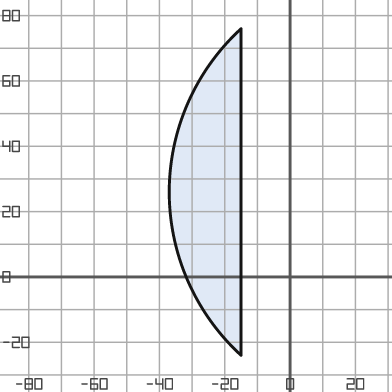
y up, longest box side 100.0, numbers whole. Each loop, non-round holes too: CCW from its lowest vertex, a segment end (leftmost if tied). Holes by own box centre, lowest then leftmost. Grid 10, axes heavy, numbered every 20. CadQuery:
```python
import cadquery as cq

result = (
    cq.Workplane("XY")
    .moveTo(-15.0, -24.0)
    .lineTo(-15.0, 76.0)
    .threePointArc((-37.0, 26.0), (-15.0, -24.0))
    .close()
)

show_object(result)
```